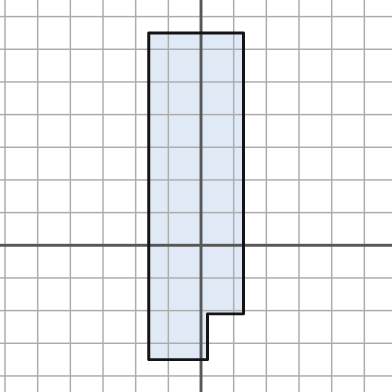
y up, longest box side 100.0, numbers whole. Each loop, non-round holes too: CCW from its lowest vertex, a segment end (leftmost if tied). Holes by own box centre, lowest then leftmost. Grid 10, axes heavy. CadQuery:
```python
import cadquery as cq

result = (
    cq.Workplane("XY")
    .moveTo(-16.0, -35.0)
    .lineTo(2.0, -35.0)
    .lineTo(2.0, -21.0)
    .lineTo(13.0, -21.0)
    .lineTo(13.0, 65.0)
    .lineTo(-16.0, 65.0)
    .close()
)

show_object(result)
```